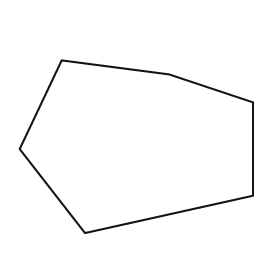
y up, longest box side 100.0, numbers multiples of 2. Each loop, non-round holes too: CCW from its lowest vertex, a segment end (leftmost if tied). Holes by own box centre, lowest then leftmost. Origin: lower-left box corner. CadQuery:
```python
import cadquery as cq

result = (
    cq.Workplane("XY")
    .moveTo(28.0, 0.0)
    .lineTo(100.0, 16.0)
    .lineTo(100.0, 56.0)
    .lineTo(64.0, 68.0)
    .lineTo(18.0, 74.0)
    .lineTo(0.0, 36.0)
    .close()
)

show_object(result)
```